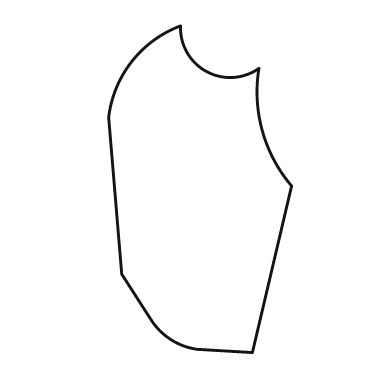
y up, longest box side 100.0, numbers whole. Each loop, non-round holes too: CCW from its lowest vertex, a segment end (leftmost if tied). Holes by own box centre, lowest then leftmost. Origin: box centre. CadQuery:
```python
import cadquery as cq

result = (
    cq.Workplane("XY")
    .moveTo(16.0, -50.0)
    .lineTo(28.0, 1.0)
    .threePointArc((19.0, 18.0), (18.0, 37.0))
    .threePointArc((2.0, 36.0), (-6.0, 50.0))
    .threePointArc((-21.0, 39.0), (-28.0, 22.0))
    .lineTo(-24.0, -26.0)
    .lineTo(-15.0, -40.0)
    .threePointArc((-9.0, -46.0), (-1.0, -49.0))
    .close()
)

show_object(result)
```